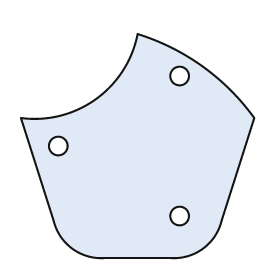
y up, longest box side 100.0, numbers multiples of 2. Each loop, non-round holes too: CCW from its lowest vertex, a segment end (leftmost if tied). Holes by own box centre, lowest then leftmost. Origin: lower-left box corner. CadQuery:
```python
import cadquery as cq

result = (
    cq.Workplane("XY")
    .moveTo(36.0, 0.0)
    .lineTo(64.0, 0.0)
    .threePointArc((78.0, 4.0), (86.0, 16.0))
    .lineTo(100.0, 60.0)
    .threePointArc((78.0, 82.0), (50.0, 96.0))
    .threePointArc((32.0, 68.0), (0.0, 60.0))
    .lineTo(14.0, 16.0)
    .threePointArc((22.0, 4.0), (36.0, 0.0))
    .close()
    .moveTo(68.0, 18.0)
    .circle(4.0)
    .moveTo(16.0, 48.0)
    .circle(4.0)
    .moveTo(68.0, 78.0)
    .circle(4.0)
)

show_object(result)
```